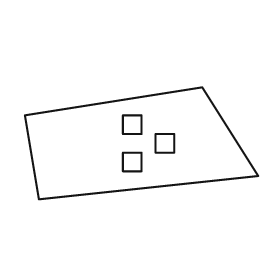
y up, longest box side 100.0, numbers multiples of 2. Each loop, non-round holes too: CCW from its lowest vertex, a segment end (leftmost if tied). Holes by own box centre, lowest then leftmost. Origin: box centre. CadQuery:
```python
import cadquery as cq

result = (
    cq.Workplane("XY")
    .moveTo(-44.0, -24.0)
    .lineTo(50.0, -14.0)
    .lineTo(26.0, 24.0)
    .lineTo(-50.0, 12.0)
    .close()
    .moveTo(-8.0, -12.0)
    .lineTo(0.0, -12.0)
    .lineTo(0.0, -4.0)
    .lineTo(-8.0, -4.0)
    .close()
    .moveTo(6.0, -4.0)
    .lineTo(14.0, -4.0)
    .lineTo(14.0, 4.0)
    .lineTo(6.0, 4.0)
    .close()
    .moveTo(-8.0, 4.0)
    .lineTo(0.0, 4.0)
    .lineTo(0.0, 12.0)
    .lineTo(-8.0, 12.0)
    .close()
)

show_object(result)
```